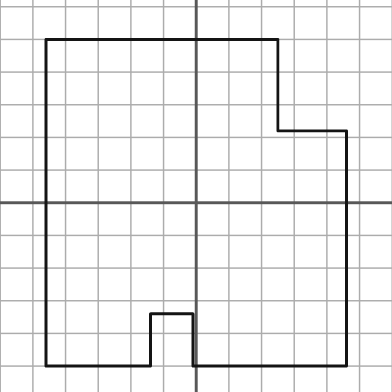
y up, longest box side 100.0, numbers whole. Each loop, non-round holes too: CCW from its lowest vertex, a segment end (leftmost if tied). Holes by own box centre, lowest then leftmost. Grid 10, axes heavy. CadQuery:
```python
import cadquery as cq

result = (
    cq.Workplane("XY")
    .moveTo(-46.0, -50.0)
    .lineTo(-14.0, -50.0)
    .lineTo(-14.0, -34.0)
    .lineTo(-1.0, -34.0)
    .lineTo(-1.0, -50.0)
    .lineTo(46.0, -50.0)
    .lineTo(46.0, 22.0)
    .lineTo(25.0, 22.0)
    .lineTo(25.0, 50.0)
    .lineTo(-46.0, 50.0)
    .close()
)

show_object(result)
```